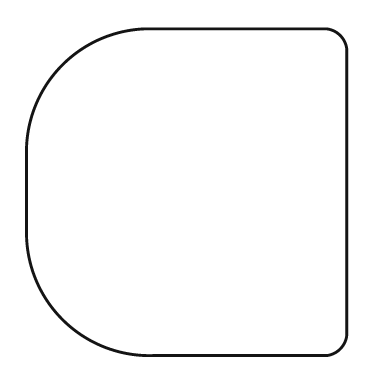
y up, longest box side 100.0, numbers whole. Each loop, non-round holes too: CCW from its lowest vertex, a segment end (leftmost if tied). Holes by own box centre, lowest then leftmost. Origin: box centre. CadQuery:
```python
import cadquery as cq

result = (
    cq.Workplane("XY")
    .moveTo(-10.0, -50.0)
    .lineTo(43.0, -50.0)
    .threePointArc((47.0, -48.0), (49.0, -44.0))
    .lineTo(49.0, 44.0)
    .threePointArc((47.0, 48.0), (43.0, 50.0))
    .lineTo(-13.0, 50.0)
    .threePointArc((-38.0, 39.0), (-49.0, 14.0))
    .lineTo(-49.0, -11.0)
    .threePointArc((-38.0, -39.0), (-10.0, -50.0))
    .close()
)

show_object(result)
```